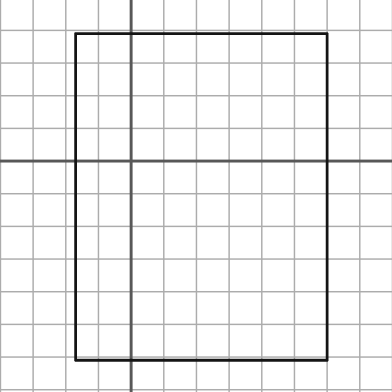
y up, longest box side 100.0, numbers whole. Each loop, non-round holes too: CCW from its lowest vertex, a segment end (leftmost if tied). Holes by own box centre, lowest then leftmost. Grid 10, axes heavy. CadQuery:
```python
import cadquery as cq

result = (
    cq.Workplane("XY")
    .moveTo(-17.0, -61.0)
    .lineTo(60.0, -61.0)
    .lineTo(60.0, 39.0)
    .lineTo(-17.0, 39.0)
    .close()
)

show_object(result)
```